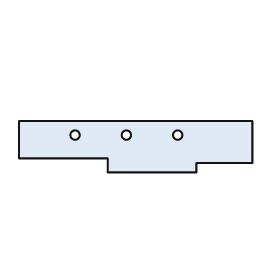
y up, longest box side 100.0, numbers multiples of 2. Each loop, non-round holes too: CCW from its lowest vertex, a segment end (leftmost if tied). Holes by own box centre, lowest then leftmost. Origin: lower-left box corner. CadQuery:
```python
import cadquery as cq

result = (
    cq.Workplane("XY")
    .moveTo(38.0, 0.0)
    .lineTo(76.0, 0.0)
    .lineTo(76.0, 4.0)
    .lineTo(100.0, 4.0)
    .lineTo(100.0, 22.0)
    .lineTo(0.0, 22.0)
    .lineTo(0.0, 6.0)
    .lineTo(38.0, 6.0)
    .close()
    .moveTo(24.0, 16.0)
    .circle(2.0)
    .moveTo(46.0, 16.0)
    .circle(2.0)
    .moveTo(68.0, 16.0)
    .circle(2.0)
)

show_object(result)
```